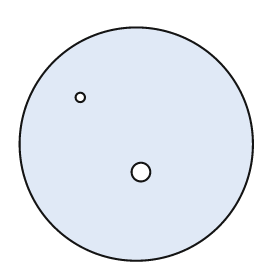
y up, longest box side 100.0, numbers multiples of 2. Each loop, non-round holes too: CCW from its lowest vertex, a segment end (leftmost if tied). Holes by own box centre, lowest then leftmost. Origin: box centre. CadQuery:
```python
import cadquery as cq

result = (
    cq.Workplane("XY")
    .moveTo(0.0, 0.0)
    .circle(50.0)
    .moveTo(2.0, -12.0)
    .circle(4.0)
    .moveTo(-24.0, 20.0)
    .circle(2.0)
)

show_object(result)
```